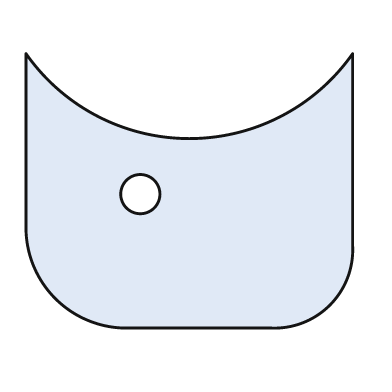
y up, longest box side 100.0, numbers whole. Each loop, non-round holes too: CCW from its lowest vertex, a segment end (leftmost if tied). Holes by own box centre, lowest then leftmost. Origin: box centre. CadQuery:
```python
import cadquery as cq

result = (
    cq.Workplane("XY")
    .moveTo(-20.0, -42.0)
    .lineTo(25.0, -42.0)
    .threePointArc((43.0, -35.0), (50.0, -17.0))
    .lineTo(50.0, 42.0)
    .threePointArc((0.0, 16.0), (-50.0, 42.0))
    .lineTo(-50.0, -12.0)
    .threePointArc((-41.0, -33.0), (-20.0, -42.0))
    .close()
    .moveTo(-15.0, -1.0)
    .circle(6.0)
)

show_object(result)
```